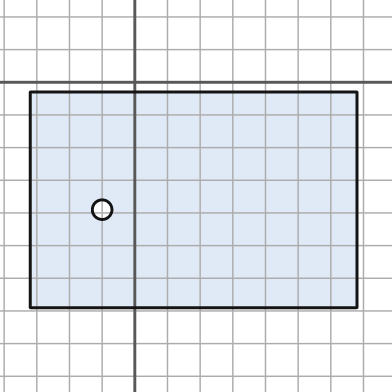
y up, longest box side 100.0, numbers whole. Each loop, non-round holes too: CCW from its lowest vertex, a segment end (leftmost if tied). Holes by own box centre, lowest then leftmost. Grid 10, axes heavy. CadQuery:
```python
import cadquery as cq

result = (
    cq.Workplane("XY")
    .moveTo(-32.0, -69.0)
    .lineTo(68.0, -69.0)
    .lineTo(68.0, -3.0)
    .lineTo(-32.0, -3.0)
    .close()
    .moveTo(-10.0, -39.0)
    .circle(3.0)
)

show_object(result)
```